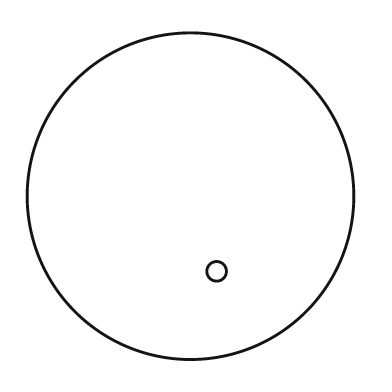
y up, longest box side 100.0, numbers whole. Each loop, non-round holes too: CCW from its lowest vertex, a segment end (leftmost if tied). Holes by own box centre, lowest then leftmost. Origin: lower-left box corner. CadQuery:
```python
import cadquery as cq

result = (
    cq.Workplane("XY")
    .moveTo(50.0, 50.0)
    .circle(50.0)
    .moveTo(58.0, 27.0)
    .circle(3.0)
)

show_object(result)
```